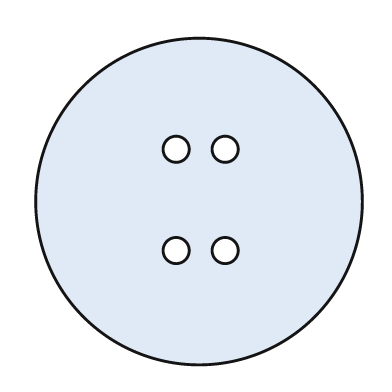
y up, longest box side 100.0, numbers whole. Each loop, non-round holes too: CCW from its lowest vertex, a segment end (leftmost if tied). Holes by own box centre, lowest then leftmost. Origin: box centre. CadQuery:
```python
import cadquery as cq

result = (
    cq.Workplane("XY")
    .moveTo(0.0, 0.0)
    .circle(50.0)
    .moveTo(-7.0, -15.0)
    .circle(4.0)
    .moveTo(8.0, -15.0)
    .circle(4.0)
    .moveTo(-7.0, 16.0)
    .circle(4.0)
    .moveTo(8.0, 16.0)
    .circle(4.0)
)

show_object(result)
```